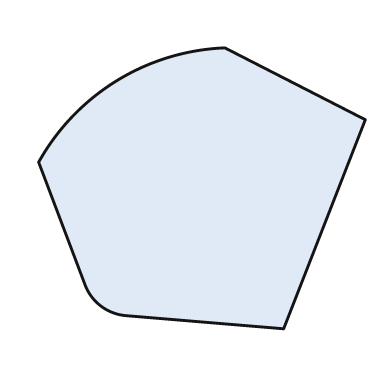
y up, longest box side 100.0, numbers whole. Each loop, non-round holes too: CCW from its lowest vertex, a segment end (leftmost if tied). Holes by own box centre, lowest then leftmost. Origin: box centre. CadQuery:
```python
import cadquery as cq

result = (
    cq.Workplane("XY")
    .moveTo(25.0, -43.0)
    .lineTo(50.0, 21.0)
    .lineTo(7.0, 43.0)
    .threePointArc((-26.0, 33.0), (-50.0, 8.0))
    .lineTo(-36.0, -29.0)
    .threePointArc((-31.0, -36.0), (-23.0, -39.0))
    .close()
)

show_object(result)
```